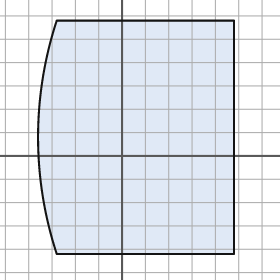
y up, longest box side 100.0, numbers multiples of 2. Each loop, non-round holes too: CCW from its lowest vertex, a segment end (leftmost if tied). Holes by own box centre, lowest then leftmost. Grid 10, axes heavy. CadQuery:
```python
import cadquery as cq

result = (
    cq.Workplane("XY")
    .moveTo(-28.0, -42.0)
    .lineTo(48.0, -42.0)
    .lineTo(48.0, 58.0)
    .lineTo(-28.0, 58.0)
    .threePointArc((-36.0, 8.0), (-28.0, -42.0))
    .close()
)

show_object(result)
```